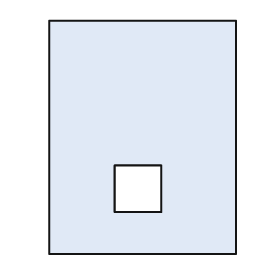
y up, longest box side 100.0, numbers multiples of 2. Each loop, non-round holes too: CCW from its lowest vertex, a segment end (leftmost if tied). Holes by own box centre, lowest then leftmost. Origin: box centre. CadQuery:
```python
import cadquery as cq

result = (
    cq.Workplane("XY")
    .moveTo(-40.0, -50.0)
    .lineTo(40.0, -50.0)
    .lineTo(40.0, 50.0)
    .lineTo(-40.0, 50.0)
    .close()
    .moveTo(-12.0, -32.0)
    .lineTo(8.0, -32.0)
    .lineTo(8.0, -12.0)
    .lineTo(-12.0, -12.0)
    .close()
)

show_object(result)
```